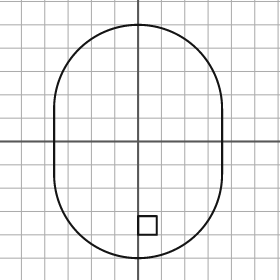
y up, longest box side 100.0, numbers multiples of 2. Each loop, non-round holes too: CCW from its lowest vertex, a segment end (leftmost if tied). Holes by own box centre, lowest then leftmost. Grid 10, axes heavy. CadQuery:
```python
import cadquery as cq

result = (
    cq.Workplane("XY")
    .moveTo(-36.0, -14.0)
    .threePointArc((0.0, -50.0), (36.0, -14.0))
    .lineTo(36.0, 14.0)
    .threePointArc((0.0, 50.0), (-36.0, 14.0))
    .close()
    .moveTo(0.0, -40.0)
    .lineTo(8.0, -40.0)
    .lineTo(8.0, -32.0)
    .lineTo(0.0, -32.0)
    .close()
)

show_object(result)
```